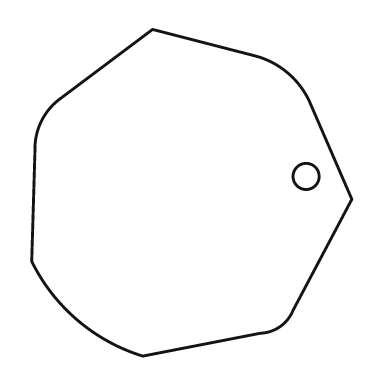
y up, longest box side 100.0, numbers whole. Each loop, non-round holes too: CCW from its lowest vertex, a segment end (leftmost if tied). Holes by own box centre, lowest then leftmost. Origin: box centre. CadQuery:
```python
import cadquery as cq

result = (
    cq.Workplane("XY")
    .moveTo(-15.0, -50.0)
    .lineTo(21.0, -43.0)
    .threePointArc((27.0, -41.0), (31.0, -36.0))
    .lineTo(49.0, -2.0)
    .lineTo(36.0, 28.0)
    .threePointArc((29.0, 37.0), (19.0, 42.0))
    .lineTo(-12.0, 50.0)
    .lineTo(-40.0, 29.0)
    .threePointArc((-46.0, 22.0), (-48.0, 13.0))
    .lineTo(-49.0, -21.0)
    .threePointArc((-35.0, -39.0), (-15.0, -50.0))
    .close()
    .moveTo(35.0, 5.0)
    .circle(4.0)
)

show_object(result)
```